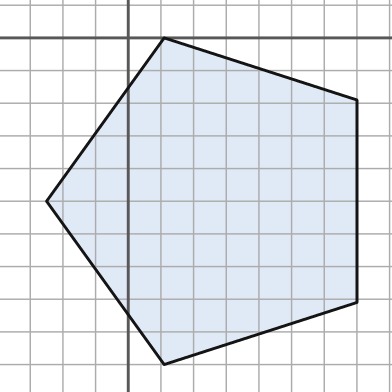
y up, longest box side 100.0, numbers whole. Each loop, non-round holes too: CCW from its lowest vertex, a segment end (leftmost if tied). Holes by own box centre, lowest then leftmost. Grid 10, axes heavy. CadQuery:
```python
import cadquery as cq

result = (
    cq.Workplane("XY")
    .moveTo(11.0, -100.0)
    .lineTo(70.0, -81.0)
    .lineTo(70.0, -19.0)
    .lineTo(11.0, 0.0)
    .lineTo(-25.0, -50.0)
    .close()
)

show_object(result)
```